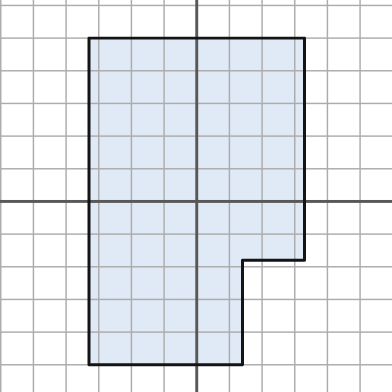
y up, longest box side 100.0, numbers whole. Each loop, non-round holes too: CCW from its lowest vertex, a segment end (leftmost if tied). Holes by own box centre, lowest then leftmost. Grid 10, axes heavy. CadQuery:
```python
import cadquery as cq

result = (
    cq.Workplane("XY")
    .moveTo(-33.0, -50.0)
    .lineTo(14.0, -50.0)
    .lineTo(14.0, -18.0)
    .lineTo(33.0, -18.0)
    .lineTo(33.0, 50.0)
    .lineTo(-33.0, 50.0)
    .close()
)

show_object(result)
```